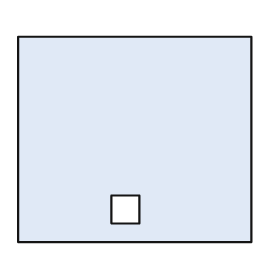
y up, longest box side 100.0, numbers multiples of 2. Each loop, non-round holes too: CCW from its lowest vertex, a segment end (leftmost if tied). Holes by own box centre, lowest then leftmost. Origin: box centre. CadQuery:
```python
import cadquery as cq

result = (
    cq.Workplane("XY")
    .moveTo(-50.0, -44.0)
    .lineTo(50.0, -44.0)
    .lineTo(50.0, 44.0)
    .lineTo(-50.0, 44.0)
    .close()
    .moveTo(-10.0, -36.0)
    .lineTo(2.0, -36.0)
    .lineTo(2.0, -24.0)
    .lineTo(-10.0, -24.0)
    .close()
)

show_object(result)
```